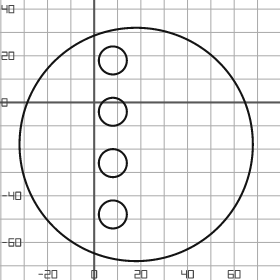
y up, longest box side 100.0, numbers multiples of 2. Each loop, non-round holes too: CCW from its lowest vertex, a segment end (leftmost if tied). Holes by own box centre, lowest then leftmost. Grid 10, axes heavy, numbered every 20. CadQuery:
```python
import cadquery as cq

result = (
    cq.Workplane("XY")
    .moveTo(18.0, -18.0)
    .circle(50.0)
    .moveTo(8.0, -48.0)
    .circle(6.0)
    .moveTo(8.0, -26.0)
    .circle(6.0)
    .moveTo(8.0, -4.0)
    .circle(6.0)
    .moveTo(8.0, 18.0)
    .circle(6.0)
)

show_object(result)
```